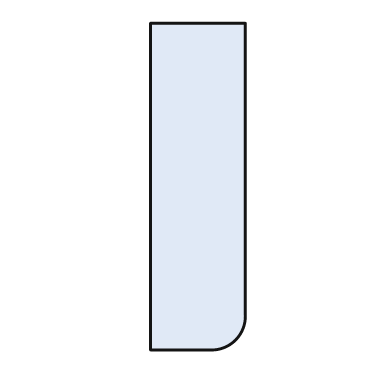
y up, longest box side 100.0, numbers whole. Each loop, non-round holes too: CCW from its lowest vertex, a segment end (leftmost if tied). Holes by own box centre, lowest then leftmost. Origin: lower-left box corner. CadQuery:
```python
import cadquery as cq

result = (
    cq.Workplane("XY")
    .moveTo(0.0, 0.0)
    .lineTo(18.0, 0.0)
    .threePointArc((26.0, 3.0), (29.0, 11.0))
    .lineTo(29.0, 100.0)
    .lineTo(0.0, 100.0)
    .close()
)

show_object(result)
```